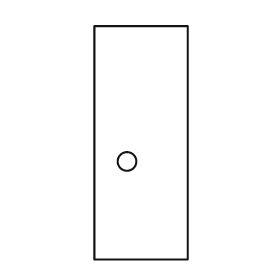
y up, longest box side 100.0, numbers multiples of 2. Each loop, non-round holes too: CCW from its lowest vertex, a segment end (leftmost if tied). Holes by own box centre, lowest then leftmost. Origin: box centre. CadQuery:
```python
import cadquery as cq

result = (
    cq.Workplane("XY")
    .moveTo(-20.0, -50.0)
    .lineTo(20.0, -50.0)
    .lineTo(20.0, 50.0)
    .lineTo(-20.0, 50.0)
    .close()
    .moveTo(-6.0, -8.0)
    .circle(4.0)
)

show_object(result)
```